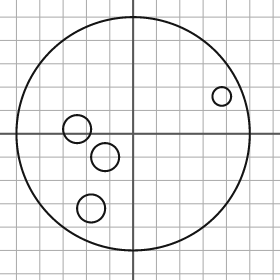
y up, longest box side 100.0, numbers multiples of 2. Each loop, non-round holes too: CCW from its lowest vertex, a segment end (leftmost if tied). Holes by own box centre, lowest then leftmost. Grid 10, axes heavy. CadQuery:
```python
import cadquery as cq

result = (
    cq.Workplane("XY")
    .moveTo(0.0, 0.0)
    .circle(50.0)
    .moveTo(-18.0, -32.0)
    .circle(6.0)
    .moveTo(-12.0, -10.0)
    .circle(6.0)
    .moveTo(-24.0, 2.0)
    .circle(6.0)
    .moveTo(38.0, 16.0)
    .circle(4.0)
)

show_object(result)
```